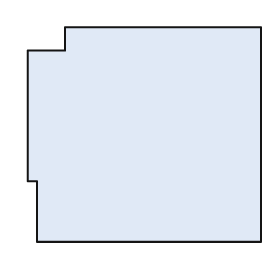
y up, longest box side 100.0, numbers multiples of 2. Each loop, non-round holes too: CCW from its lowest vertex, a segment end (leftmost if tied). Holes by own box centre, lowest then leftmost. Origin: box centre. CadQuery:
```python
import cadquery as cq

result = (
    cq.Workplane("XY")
    .moveTo(-46.0, -46.0)
    .lineTo(50.0, -46.0)
    .lineTo(50.0, 46.0)
    .lineTo(-34.0, 46.0)
    .lineTo(-34.0, 36.0)
    .lineTo(-50.0, 36.0)
    .lineTo(-50.0, -20.0)
    .lineTo(-46.0, -20.0)
    .close()
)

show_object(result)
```